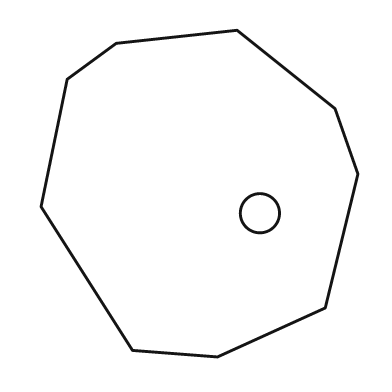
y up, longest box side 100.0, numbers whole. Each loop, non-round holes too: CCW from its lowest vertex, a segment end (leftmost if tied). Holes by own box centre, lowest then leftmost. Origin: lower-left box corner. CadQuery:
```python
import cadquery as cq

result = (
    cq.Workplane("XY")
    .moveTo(54.0, 0.0)
    .lineTo(87.0, 15.0)
    .lineTo(97.0, 56.0)
    .lineTo(90.0, 76.0)
    .lineTo(60.0, 100.0)
    .lineTo(23.0, 96.0)
    .lineTo(8.0, 85.0)
    .lineTo(0.0, 46.0)
    .lineTo(28.0, 2.0)
    .close()
    .moveTo(67.0, 44.0)
    .circle(6.0)
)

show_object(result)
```